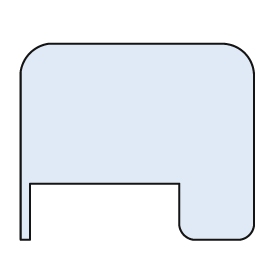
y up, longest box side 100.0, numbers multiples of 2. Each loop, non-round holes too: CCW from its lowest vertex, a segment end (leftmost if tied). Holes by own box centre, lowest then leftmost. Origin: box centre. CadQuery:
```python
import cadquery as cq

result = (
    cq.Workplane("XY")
    .moveTo(-50.0, -42.0)
    .lineTo(-46.0, -42.0)
    .lineTo(-46.0, -18.0)
    .lineTo(18.0, -18.0)
    .lineTo(18.0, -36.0)
    .threePointArc((20.0, -40.0), (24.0, -42.0))
    .lineTo(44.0, -42.0)
    .threePointArc((48.0, -40.0), (50.0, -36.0))
    .lineTo(50.0, 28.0)
    .threePointArc((46.0, 38.0), (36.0, 42.0))
    .lineTo(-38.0, 42.0)
    .threePointArc((-46.0, 38.0), (-50.0, 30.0))
    .close()
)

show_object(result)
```